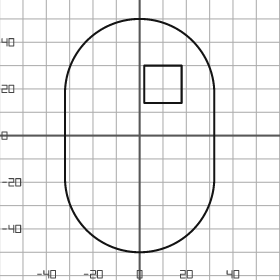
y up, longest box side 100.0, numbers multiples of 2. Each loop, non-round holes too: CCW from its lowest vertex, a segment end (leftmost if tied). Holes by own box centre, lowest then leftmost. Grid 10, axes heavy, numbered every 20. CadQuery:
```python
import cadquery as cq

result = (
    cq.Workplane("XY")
    .moveTo(-32.0, -18.0)
    .threePointArc((0.0, -50.0), (32.0, -18.0))
    .lineTo(32.0, 18.0)
    .threePointArc((0.0, 50.0), (-32.0, 18.0))
    .close()
    .moveTo(2.0, 14.0)
    .lineTo(18.0, 14.0)
    .lineTo(18.0, 30.0)
    .lineTo(2.0, 30.0)
    .close()
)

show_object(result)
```